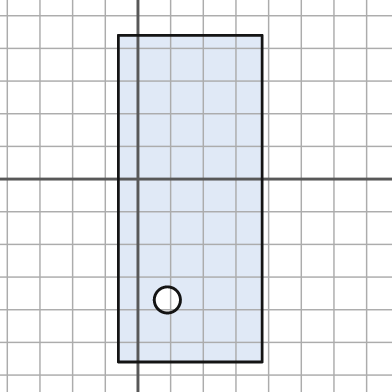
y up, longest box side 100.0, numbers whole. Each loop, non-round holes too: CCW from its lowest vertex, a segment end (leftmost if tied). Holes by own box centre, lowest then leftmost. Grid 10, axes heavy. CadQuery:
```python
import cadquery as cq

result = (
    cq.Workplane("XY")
    .moveTo(-6.0, -56.0)
    .lineTo(38.0, -56.0)
    .lineTo(38.0, 44.0)
    .lineTo(-6.0, 44.0)
    .close()
    .moveTo(9.0, -37.0)
    .circle(4.0)
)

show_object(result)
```